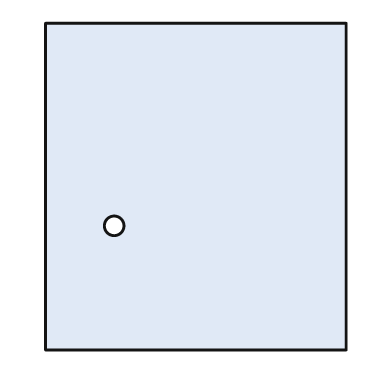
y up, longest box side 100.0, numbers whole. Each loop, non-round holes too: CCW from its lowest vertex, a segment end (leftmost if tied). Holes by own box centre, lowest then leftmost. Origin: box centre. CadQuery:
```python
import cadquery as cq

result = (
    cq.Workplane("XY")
    .moveTo(-46.0, -50.0)
    .lineTo(46.0, -50.0)
    .lineTo(46.0, 50.0)
    .lineTo(-46.0, 50.0)
    .close()
    .moveTo(-25.0, -12.0)
    .circle(3.0)
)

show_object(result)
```